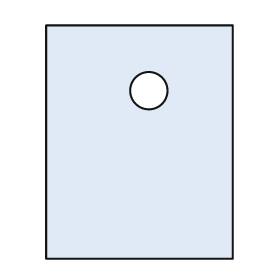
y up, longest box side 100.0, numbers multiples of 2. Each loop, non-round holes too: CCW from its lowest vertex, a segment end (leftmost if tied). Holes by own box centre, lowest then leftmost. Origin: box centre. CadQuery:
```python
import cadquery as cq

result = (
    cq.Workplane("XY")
    .moveTo(-40.0, -50.0)
    .lineTo(40.0, -50.0)
    .lineTo(40.0, 50.0)
    .lineTo(-40.0, 50.0)
    .close()
    .moveTo(4.0, 22.0)
    .circle(8.0)
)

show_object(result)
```